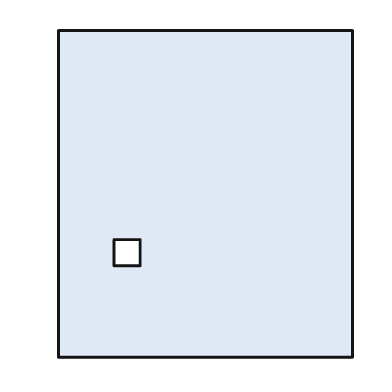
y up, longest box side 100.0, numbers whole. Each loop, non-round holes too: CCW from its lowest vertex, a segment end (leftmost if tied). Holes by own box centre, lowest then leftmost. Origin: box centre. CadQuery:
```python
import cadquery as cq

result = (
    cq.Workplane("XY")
    .moveTo(-45.0, -50.0)
    .lineTo(45.0, -50.0)
    .lineTo(45.0, 50.0)
    .lineTo(-45.0, 50.0)
    .close()
    .moveTo(-28.0, -22.0)
    .lineTo(-20.0, -22.0)
    .lineTo(-20.0, -14.0)
    .lineTo(-28.0, -14.0)
    .close()
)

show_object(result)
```